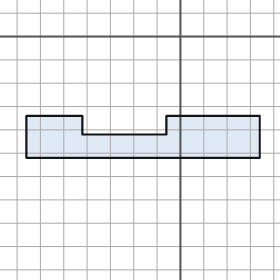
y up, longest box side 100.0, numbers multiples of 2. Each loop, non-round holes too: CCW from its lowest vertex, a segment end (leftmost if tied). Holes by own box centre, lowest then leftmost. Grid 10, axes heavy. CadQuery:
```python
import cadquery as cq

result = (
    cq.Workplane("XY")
    .moveTo(-66.0, -52.0)
    .lineTo(34.0, -52.0)
    .lineTo(34.0, -34.0)
    .lineTo(-6.0, -34.0)
    .lineTo(-6.0, -42.0)
    .lineTo(-42.0, -42.0)
    .lineTo(-42.0, -34.0)
    .lineTo(-66.0, -34.0)
    .close()
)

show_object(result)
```